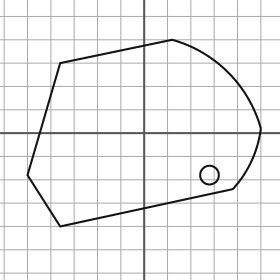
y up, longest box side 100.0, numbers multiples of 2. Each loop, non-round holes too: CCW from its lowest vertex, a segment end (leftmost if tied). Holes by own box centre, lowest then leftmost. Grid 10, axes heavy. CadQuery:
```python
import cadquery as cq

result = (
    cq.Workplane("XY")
    .moveTo(-36.0, -40.0)
    .lineTo(38.0, -24.0)
    .threePointArc((46.0, -12.0), (50.0, 2.0))
    .threePointArc((36.0, 26.0), (12.0, 40.0))
    .lineTo(-36.0, 30.0)
    .lineTo(-50.0, -18.0)
    .close()
    .moveTo(28.0, -18.0)
    .circle(4.0)
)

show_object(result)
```